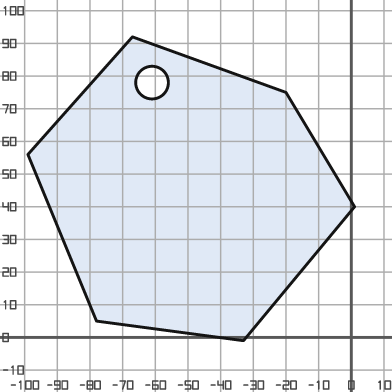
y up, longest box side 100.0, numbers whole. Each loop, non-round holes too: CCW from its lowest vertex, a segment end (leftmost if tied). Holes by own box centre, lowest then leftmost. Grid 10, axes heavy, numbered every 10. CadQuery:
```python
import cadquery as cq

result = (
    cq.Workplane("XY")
    .moveTo(-33.0, -1.0)
    .lineTo(1.0, 40.0)
    .lineTo(-20.0, 75.0)
    .lineTo(-67.0, 92.0)
    .lineTo(-99.0, 56.0)
    .lineTo(-78.0, 5.0)
    .close()
    .moveTo(-61.0, 78.0)
    .circle(5.0)
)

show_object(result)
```